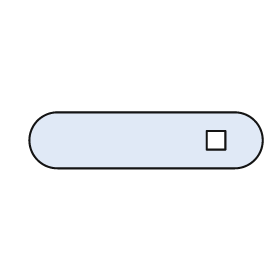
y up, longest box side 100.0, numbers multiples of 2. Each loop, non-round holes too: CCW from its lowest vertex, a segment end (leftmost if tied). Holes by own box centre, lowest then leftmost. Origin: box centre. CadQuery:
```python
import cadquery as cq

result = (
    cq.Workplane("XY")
    .moveTo(-38.0, -12.0)
    .lineTo(38.0, -12.0)
    .threePointArc((50.0, 0.0), (38.0, 12.0))
    .lineTo(-38.0, 12.0)
    .threePointArc((-50.0, 0.0), (-38.0, -12.0))
    .close()
    .moveTo(26.0, -4.0)
    .lineTo(34.0, -4.0)
    .lineTo(34.0, 4.0)
    .lineTo(26.0, 4.0)
    .close()
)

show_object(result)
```